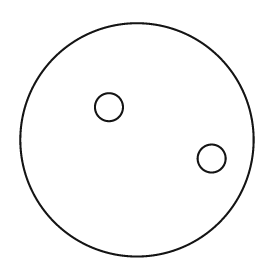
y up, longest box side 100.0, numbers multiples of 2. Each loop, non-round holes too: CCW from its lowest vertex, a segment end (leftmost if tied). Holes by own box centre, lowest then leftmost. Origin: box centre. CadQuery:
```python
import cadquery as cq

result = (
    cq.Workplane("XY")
    .moveTo(0.0, 0.0)
    .circle(50.0)
    .moveTo(32.0, -8.0)
    .circle(6.0)
    .moveTo(-12.0, 14.0)
    .circle(6.0)
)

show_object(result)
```